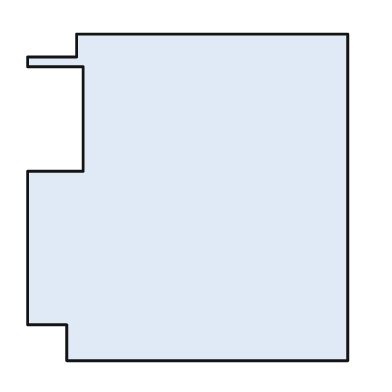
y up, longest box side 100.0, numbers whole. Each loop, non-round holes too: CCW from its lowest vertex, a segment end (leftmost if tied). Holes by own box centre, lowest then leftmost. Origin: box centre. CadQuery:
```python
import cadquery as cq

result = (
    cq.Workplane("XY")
    .moveTo(-37.0, -50.0)
    .lineTo(49.0, -50.0)
    .lineTo(49.0, 50.0)
    .lineTo(-34.0, 50.0)
    .lineTo(-34.0, 43.0)
    .lineTo(-49.0, 43.0)
    .lineTo(-49.0, 40.0)
    .lineTo(-32.0, 40.0)
    .lineTo(-32.0, 8.0)
    .lineTo(-49.0, 8.0)
    .lineTo(-49.0, -39.0)
    .lineTo(-37.0, -39.0)
    .close()
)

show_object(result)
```